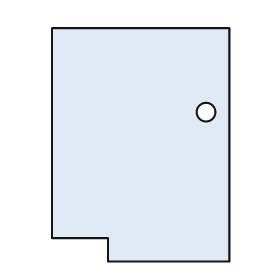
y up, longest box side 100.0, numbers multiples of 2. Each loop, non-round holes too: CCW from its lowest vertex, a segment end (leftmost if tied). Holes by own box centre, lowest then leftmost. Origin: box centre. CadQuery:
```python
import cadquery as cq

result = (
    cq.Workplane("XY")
    .moveTo(-14.0, -50.0)
    .lineTo(38.0, -50.0)
    .lineTo(38.0, 50.0)
    .lineTo(-38.0, 50.0)
    .lineTo(-38.0, -40.0)
    .lineTo(-14.0, -40.0)
    .close()
    .moveTo(28.0, 14.0)
    .circle(4.0)
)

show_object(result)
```